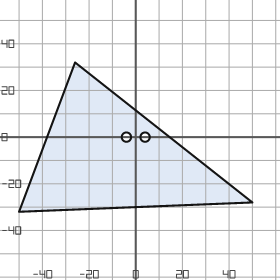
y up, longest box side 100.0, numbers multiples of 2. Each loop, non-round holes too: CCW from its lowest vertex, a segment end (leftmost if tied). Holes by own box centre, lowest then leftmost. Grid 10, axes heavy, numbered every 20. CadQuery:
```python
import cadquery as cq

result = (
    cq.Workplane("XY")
    .moveTo(-50.0, -32.0)
    .lineTo(50.0, -28.0)
    .lineTo(-26.0, 32.0)
    .close()
    .moveTo(-4.0, 0.0)
    .circle(2.0)
    .moveTo(4.0, 0.0)
    .circle(2.0)
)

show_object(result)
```